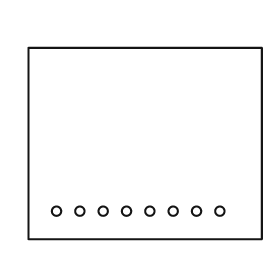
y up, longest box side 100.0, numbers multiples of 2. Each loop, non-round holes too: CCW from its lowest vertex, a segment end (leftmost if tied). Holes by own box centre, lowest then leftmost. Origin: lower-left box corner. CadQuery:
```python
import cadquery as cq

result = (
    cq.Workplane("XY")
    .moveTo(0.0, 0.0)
    .lineTo(100.0, 0.0)
    .lineTo(100.0, 82.0)
    .lineTo(0.0, 82.0)
    .close()
    .moveTo(12.0, 12.0)
    .circle(2.0)
    .moveTo(22.0, 12.0)
    .circle(2.0)
    .moveTo(32.0, 12.0)
    .circle(2.0)
    .moveTo(42.0, 12.0)
    .circle(2.0)
    .moveTo(52.0, 12.0)
    .circle(2.0)
    .moveTo(62.0, 12.0)
    .circle(2.0)
    .moveTo(72.0, 12.0)
    .circle(2.0)
    .moveTo(82.0, 12.0)
    .circle(2.0)
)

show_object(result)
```